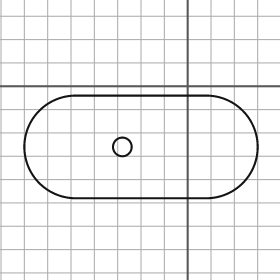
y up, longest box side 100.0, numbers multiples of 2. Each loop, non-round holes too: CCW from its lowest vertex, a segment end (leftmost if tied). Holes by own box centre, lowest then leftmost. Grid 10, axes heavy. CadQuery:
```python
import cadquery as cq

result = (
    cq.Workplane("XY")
    .moveTo(-48.0, -48.0)
    .lineTo(8.0, -48.0)
    .threePointArc((30.0, -26.0), (8.0, -4.0))
    .lineTo(-48.0, -4.0)
    .threePointArc((-70.0, -26.0), (-48.0, -48.0))
    .close()
    .moveTo(-28.0, -26.0)
    .circle(4.0)
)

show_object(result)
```